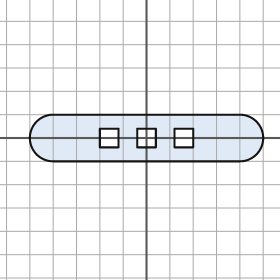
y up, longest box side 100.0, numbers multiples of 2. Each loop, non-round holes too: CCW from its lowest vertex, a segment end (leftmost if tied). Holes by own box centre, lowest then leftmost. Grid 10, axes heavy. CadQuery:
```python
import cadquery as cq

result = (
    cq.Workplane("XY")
    .moveTo(-40.0, -10.0)
    .lineTo(40.0, -10.0)
    .threePointArc((50.0, 0.0), (40.0, 10.0))
    .lineTo(-40.0, 10.0)
    .threePointArc((-50.0, 0.0), (-40.0, -10.0))
    .close()
    .moveTo(-20.0, -4.0)
    .lineTo(-12.0, -4.0)
    .lineTo(-12.0, 4.0)
    .lineTo(-20.0, 4.0)
    .close()
    .moveTo(-4.0, -4.0)
    .lineTo(4.0, -4.0)
    .lineTo(4.0, 4.0)
    .lineTo(-4.0, 4.0)
    .close()
    .moveTo(12.0, -4.0)
    .lineTo(20.0, -4.0)
    .lineTo(20.0, 4.0)
    .lineTo(12.0, 4.0)
    .close()
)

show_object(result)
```